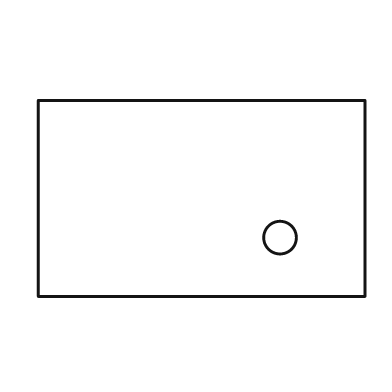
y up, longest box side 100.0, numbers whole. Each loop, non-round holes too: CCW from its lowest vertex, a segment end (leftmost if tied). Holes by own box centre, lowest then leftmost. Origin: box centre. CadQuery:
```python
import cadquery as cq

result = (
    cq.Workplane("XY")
    .moveTo(-50.0, -30.0)
    .lineTo(50.0, -30.0)
    .lineTo(50.0, 30.0)
    .lineTo(-50.0, 30.0)
    .close()
    .moveTo(24.0, -12.0)
    .circle(5.0)
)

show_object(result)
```